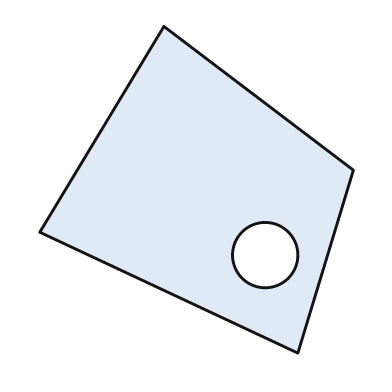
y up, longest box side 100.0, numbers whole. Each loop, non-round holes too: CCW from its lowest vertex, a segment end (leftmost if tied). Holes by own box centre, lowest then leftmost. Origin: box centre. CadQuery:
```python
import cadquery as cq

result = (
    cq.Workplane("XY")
    .moveTo(31.0, -50.0)
    .lineTo(48.0, 6.0)
    .lineTo(-10.0, 50.0)
    .lineTo(-48.0, -13.0)
    .close()
    .moveTo(21.0, -20.0)
    .circle(10.0)
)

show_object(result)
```